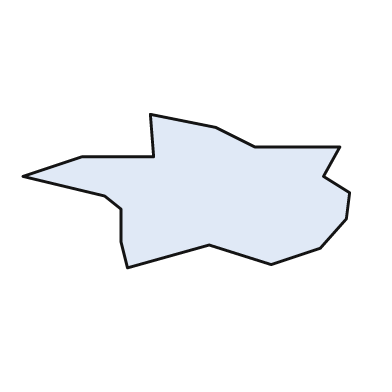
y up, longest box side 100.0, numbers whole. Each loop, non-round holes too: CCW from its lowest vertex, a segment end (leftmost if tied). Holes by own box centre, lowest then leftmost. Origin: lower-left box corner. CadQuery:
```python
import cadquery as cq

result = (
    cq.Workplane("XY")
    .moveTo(32.0, 0.0)
    .lineTo(57.0, 7.0)
    .lineTo(76.0, 1.0)
    .lineTo(91.0, 6.0)
    .lineTo(99.0, 15.0)
    .lineTo(100.0, 23.0)
    .lineTo(92.0, 28.0)
    .lineTo(97.0, 37.0)
    .lineTo(71.0, 37.0)
    .lineTo(59.0, 43.0)
    .lineTo(39.0, 47.0)
    .lineTo(40.0, 34.0)
    .lineTo(18.0, 34.0)
    .lineTo(0.0, 28.0)
    .lineTo(25.0, 22.0)
    .lineTo(30.0, 18.0)
    .lineTo(30.0, 8.0)
    .close()
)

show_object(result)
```